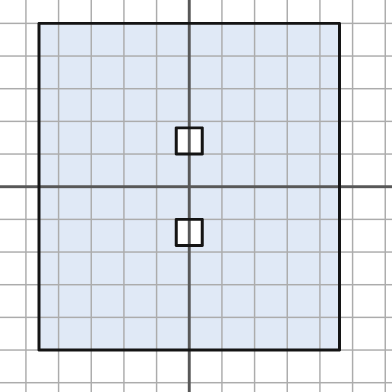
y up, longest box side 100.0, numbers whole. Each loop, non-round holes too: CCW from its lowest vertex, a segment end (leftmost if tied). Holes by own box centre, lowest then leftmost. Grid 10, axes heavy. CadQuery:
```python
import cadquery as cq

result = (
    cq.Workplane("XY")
    .moveTo(-46.0, -50.0)
    .lineTo(46.0, -50.0)
    .lineTo(46.0, 50.0)
    .lineTo(-46.0, 50.0)
    .close()
    .moveTo(-4.0, -18.0)
    .lineTo(4.0, -18.0)
    .lineTo(4.0, -10.0)
    .lineTo(-4.0, -10.0)
    .close()
    .moveTo(-4.0, 10.0)
    .lineTo(4.0, 10.0)
    .lineTo(4.0, 18.0)
    .lineTo(-4.0, 18.0)
    .close()
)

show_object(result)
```